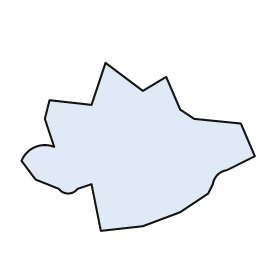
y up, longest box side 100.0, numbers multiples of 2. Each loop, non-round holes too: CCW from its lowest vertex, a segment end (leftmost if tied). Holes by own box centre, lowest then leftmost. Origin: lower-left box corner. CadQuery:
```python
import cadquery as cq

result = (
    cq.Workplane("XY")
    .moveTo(34.0, 0.0)
    .lineTo(52.0, 2.0)
    .lineTo(68.0, 8.0)
    .lineTo(80.0, 16.0)
    .lineTo(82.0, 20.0)
    .threePointArc((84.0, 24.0), (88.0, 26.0))
    .lineTo(100.0, 32.0)
    .lineTo(94.0, 46.0)
    .lineTo(74.0, 48.0)
    .lineTo(68.0, 52.0)
    .lineTo(62.0, 66.0)
    .lineTo(52.0, 60.0)
    .lineTo(36.0, 72.0)
    .lineTo(30.0, 54.0)
    .lineTo(12.0, 56.0)
    .lineTo(10.0, 48.0)
    .lineTo(14.0, 36.0)
    .threePointArc((6.0, 36.0), (0.0, 30.0))
    .lineTo(6.0, 22.0)
    .lineTo(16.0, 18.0)
    .threePointArc((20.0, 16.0), (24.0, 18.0))
    .lineTo(30.0, 20.0)
    .close()
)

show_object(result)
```